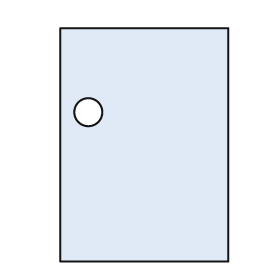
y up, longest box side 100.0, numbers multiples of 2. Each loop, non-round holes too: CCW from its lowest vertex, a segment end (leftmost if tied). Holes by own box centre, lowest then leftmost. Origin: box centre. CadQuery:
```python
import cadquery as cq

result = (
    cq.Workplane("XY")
    .moveTo(-36.0, -50.0)
    .lineTo(36.0, -50.0)
    .lineTo(36.0, 50.0)
    .lineTo(-36.0, 50.0)
    .close()
    .moveTo(-24.0, 14.0)
    .circle(6.0)
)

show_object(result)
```